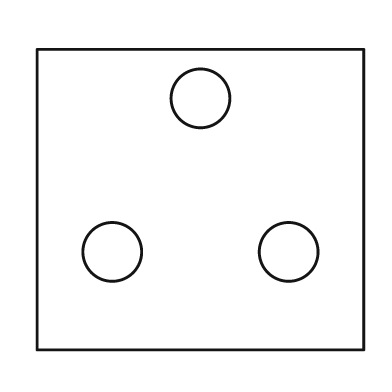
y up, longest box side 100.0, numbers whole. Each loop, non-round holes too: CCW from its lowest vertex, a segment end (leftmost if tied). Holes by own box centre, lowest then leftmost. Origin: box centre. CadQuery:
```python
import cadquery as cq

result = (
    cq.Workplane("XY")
    .moveTo(-50.0, -46.0)
    .lineTo(50.0, -46.0)
    .lineTo(50.0, 46.0)
    .lineTo(-50.0, 46.0)
    .close()
    .moveTo(-27.0, -16.0)
    .circle(9.0)
    .moveTo(27.0, -16.0)
    .circle(9.0)
    .moveTo(0.0, 31.0)
    .circle(9.0)
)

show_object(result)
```